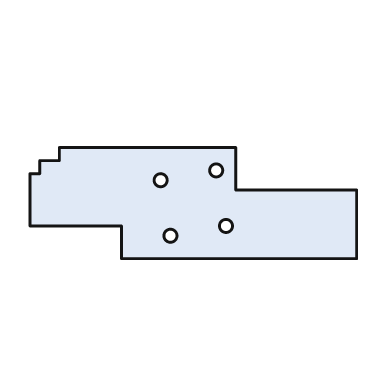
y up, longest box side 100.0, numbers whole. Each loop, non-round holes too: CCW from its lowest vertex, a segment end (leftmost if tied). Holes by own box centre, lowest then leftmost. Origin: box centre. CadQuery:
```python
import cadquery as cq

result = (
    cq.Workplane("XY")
    .moveTo(-22.0, -17.0)
    .lineTo(50.0, -17.0)
    .lineTo(50.0, 4.0)
    .lineTo(13.0, 4.0)
    .lineTo(13.0, 17.0)
    .lineTo(-41.0, 17.0)
    .lineTo(-41.0, 13.0)
    .lineTo(-47.0, 13.0)
    .lineTo(-47.0, 9.0)
    .lineTo(-50.0, 9.0)
    .lineTo(-50.0, -7.0)
    .lineTo(-22.0, -7.0)
    .close()
    .moveTo(-7.0, -10.0)
    .circle(2.0)
    .moveTo(10.0, -7.0)
    .circle(2.0)
    .moveTo(-10.0, 7.0)
    .circle(2.0)
    .moveTo(7.0, 10.0)
    .circle(2.0)
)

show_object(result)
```